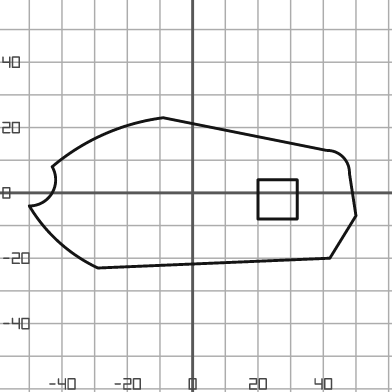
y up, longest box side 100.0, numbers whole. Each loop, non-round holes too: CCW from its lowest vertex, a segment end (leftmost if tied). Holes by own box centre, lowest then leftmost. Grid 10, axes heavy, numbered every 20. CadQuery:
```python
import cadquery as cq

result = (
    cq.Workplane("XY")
    .moveTo(-29.0, -23.0)
    .lineTo(42.0, -20.0)
    .lineTo(50.0, -7.0)
    .lineTo(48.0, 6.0)
    .threePointArc((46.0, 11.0), (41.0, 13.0))
    .lineTo(-9.0, 23.0)
    .threePointArc((-27.0, 18.0), (-43.0, 8.0))
    .threePointArc((-43.0, 0.0), (-50.0, -4.0))
    .threePointArc((-41.0, -15.0), (-29.0, -23.0))
    .close()
    .moveTo(20.0, -8.0)
    .lineTo(32.0, -8.0)
    .lineTo(32.0, 4.0)
    .lineTo(20.0, 4.0)
    .close()
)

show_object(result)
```